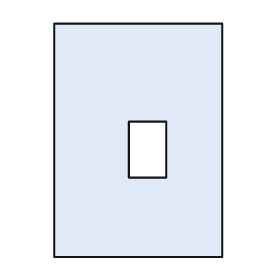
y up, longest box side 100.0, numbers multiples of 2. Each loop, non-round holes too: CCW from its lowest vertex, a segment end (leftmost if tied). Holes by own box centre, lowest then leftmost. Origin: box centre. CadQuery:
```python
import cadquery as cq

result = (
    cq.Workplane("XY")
    .moveTo(-36.0, -50.0)
    .lineTo(36.0, -50.0)
    .lineTo(36.0, 50.0)
    .lineTo(-36.0, 50.0)
    .close()
    .moveTo(-4.0, -16.0)
    .lineTo(12.0, -16.0)
    .lineTo(12.0, 8.0)
    .lineTo(-4.0, 8.0)
    .close()
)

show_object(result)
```